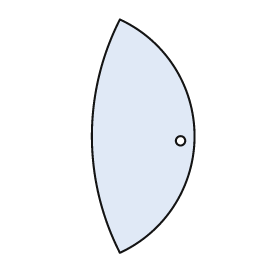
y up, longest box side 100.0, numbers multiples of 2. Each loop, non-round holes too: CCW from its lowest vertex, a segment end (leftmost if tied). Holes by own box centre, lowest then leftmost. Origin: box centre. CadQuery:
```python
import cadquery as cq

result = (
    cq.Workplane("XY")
    .moveTo(-10.0, -50.0)
    .threePointArc((22.0, 0.0), (-10.0, 50.0))
    .threePointArc((-22.0, 0.0), (-10.0, -50.0))
    .close()
    .moveTo(16.0, -2.0)
    .circle(2.0)
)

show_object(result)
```